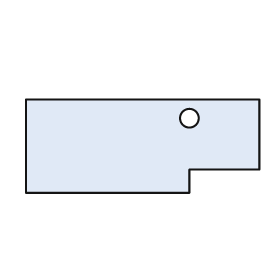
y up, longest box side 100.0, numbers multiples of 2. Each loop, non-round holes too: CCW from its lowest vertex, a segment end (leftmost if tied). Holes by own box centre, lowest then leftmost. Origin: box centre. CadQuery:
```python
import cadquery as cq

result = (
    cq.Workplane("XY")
    .moveTo(-50.0, -20.0)
    .lineTo(20.0, -20.0)
    .lineTo(20.0, -10.0)
    .lineTo(50.0, -10.0)
    .lineTo(50.0, 20.0)
    .lineTo(-50.0, 20.0)
    .close()
    .moveTo(20.0, 12.0)
    .circle(4.0)
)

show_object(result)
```